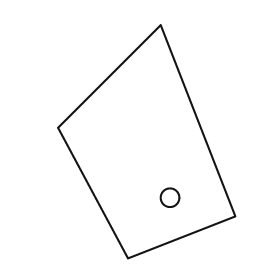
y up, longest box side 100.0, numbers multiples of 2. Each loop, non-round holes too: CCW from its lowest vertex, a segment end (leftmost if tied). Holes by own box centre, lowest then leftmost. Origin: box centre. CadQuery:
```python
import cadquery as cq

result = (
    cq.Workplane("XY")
    .moveTo(-8.0, -50.0)
    .lineTo(38.0, -32.0)
    .lineTo(6.0, 50.0)
    .lineTo(-38.0, 6.0)
    .close()
    .moveTo(10.0, -24.0)
    .circle(4.0)
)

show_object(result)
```